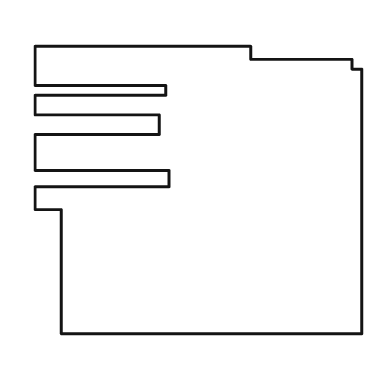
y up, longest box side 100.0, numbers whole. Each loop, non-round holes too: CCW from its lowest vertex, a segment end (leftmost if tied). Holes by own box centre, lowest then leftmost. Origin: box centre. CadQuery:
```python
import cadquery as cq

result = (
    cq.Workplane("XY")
    .moveTo(-42.0, -44.0)
    .lineTo(50.0, -44.0)
    .lineTo(50.0, 37.0)
    .lineTo(47.0, 37.0)
    .lineTo(47.0, 40.0)
    .lineTo(16.0, 40.0)
    .lineTo(16.0, 44.0)
    .lineTo(-50.0, 44.0)
    .lineTo(-50.0, 32.0)
    .lineTo(-10.0, 32.0)
    .lineTo(-10.0, 29.0)
    .lineTo(-50.0, 29.0)
    .lineTo(-50.0, 23.0)
    .lineTo(-12.0, 23.0)
    .lineTo(-12.0, 17.0)
    .lineTo(-50.0, 17.0)
    .lineTo(-50.0, 6.0)
    .lineTo(-9.0, 6.0)
    .lineTo(-9.0, 1.0)
    .lineTo(-50.0, 1.0)
    .lineTo(-50.0, -6.0)
    .lineTo(-42.0, -6.0)
    .close()
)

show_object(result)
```